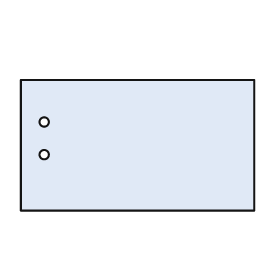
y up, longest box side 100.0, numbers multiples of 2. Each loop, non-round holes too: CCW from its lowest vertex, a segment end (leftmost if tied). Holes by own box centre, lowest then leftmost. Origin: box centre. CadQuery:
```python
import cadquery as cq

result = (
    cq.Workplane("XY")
    .moveTo(-50.0, -28.0)
    .lineTo(50.0, -28.0)
    .lineTo(50.0, 28.0)
    .lineTo(-50.0, 28.0)
    .close()
    .moveTo(-40.0, -4.0)
    .circle(2.0)
    .moveTo(-40.0, 10.0)
    .circle(2.0)
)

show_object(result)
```